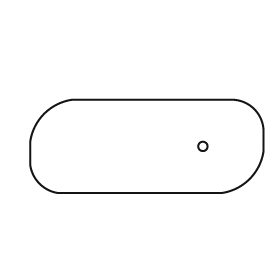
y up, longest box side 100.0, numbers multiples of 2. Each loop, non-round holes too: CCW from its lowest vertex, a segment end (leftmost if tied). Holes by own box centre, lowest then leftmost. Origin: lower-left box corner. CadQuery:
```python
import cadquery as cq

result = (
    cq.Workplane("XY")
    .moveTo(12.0, 0.0)
    .lineTo(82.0, 0.0)
    .threePointArc((94.0, 6.0), (100.0, 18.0))
    .lineTo(100.0, 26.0)
    .threePointArc((96.0, 36.0), (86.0, 40.0))
    .lineTo(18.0, 40.0)
    .threePointArc((6.0, 34.0), (0.0, 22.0))
    .lineTo(0.0, 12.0)
    .threePointArc((4.0, 4.0), (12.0, 0.0))
    .close()
    .moveTo(74.0, 20.0)
    .circle(2.0)
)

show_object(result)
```